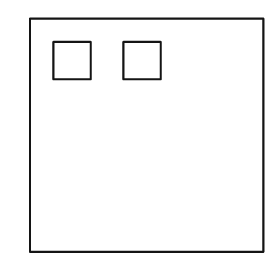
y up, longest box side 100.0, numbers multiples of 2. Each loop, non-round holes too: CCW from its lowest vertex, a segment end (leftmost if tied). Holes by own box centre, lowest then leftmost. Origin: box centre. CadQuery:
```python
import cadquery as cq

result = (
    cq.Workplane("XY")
    .moveTo(-50.0, -50.0)
    .lineTo(50.0, -50.0)
    .lineTo(50.0, 50.0)
    .lineTo(-50.0, 50.0)
    .close()
    .moveTo(-40.0, 24.0)
    .lineTo(-24.0, 24.0)
    .lineTo(-24.0, 40.0)
    .lineTo(-40.0, 40.0)
    .close()
    .moveTo(-10.0, 24.0)
    .lineTo(6.0, 24.0)
    .lineTo(6.0, 40.0)
    .lineTo(-10.0, 40.0)
    .close()
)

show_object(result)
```